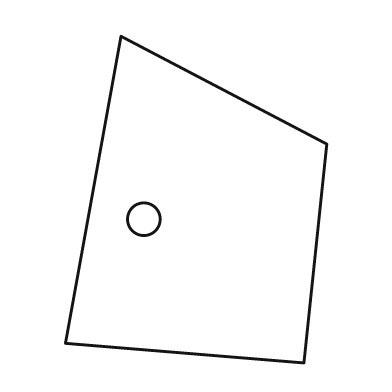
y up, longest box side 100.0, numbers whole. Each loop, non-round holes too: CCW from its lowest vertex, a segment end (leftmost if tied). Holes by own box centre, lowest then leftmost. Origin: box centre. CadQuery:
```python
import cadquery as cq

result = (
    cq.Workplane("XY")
    .moveTo(33.0, -50.0)
    .lineTo(40.0, 17.0)
    .lineTo(-23.0, 50.0)
    .lineTo(-40.0, -44.0)
    .close()
    .moveTo(-16.0, -6.0)
    .circle(5.0)
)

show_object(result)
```